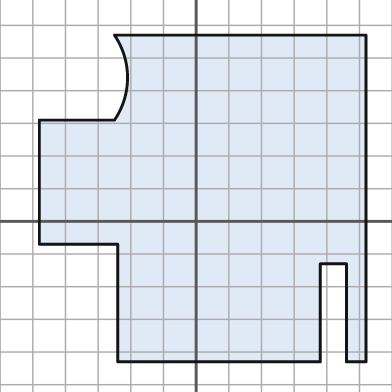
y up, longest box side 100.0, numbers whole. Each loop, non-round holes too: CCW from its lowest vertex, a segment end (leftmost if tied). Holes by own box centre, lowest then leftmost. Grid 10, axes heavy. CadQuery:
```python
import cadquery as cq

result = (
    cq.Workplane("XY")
    .moveTo(-24.0, -43.0)
    .lineTo(38.0, -43.0)
    .lineTo(38.0, -13.0)
    .lineTo(46.0, -13.0)
    .lineTo(46.0, -43.0)
    .lineTo(52.0, -43.0)
    .lineTo(52.0, 57.0)
    .lineTo(-25.0, 57.0)
    .threePointArc((-21.0, 44.0), (-25.0, 31.0))
    .lineTo(-48.0, 31.0)
    .lineTo(-48.0, -7.0)
    .lineTo(-24.0, -7.0)
    .close()
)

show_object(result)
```